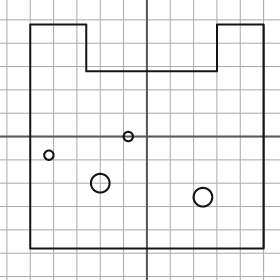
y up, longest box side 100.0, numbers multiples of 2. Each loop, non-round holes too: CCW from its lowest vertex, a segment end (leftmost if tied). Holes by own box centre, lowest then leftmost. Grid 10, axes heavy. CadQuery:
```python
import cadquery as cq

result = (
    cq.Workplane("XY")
    .moveTo(-50.0, -48.0)
    .lineTo(50.0, -48.0)
    .lineTo(50.0, 48.0)
    .lineTo(30.0, 48.0)
    .lineTo(30.0, 28.0)
    .lineTo(-26.0, 28.0)
    .lineTo(-26.0, 48.0)
    .lineTo(-50.0, 48.0)
    .close()
    .moveTo(24.0, -26.0)
    .circle(4.0)
    .moveTo(-20.0, -20.0)
    .circle(4.0)
    .moveTo(-42.0, -8.0)
    .circle(2.0)
    .moveTo(-8.0, 0.0)
    .circle(2.0)
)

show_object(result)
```